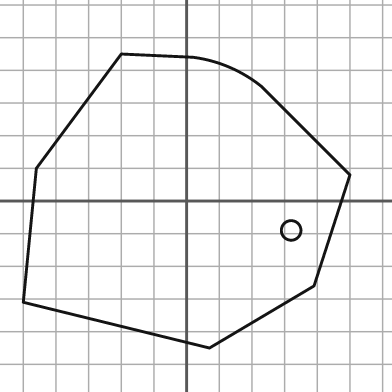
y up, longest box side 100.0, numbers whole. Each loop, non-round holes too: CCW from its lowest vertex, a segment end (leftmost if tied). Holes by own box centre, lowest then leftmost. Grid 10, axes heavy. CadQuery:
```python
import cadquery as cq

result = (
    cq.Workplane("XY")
    .moveTo(7.0, -45.0)
    .lineTo(39.0, -26.0)
    .lineTo(50.0, 8.0)
    .lineTo(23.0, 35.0)
    .threePointArc((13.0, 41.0), (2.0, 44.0))
    .lineTo(-20.0, 45.0)
    .lineTo(-46.0, 10.0)
    .lineTo(-50.0, -31.0)
    .close()
    .moveTo(32.0, -9.0)
    .circle(3.0)
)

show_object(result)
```